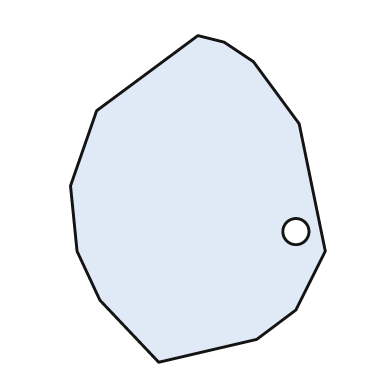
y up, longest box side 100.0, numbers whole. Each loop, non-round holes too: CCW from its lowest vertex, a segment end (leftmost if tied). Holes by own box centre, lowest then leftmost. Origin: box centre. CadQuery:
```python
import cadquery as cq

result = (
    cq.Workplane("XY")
    .moveTo(-12.0, -50.0)
    .lineTo(18.0, -43.0)
    .lineTo(30.0, -34.0)
    .lineTo(39.0, -16.0)
    .lineTo(31.0, 23.0)
    .lineTo(17.0, 42.0)
    .lineTo(8.0, 48.0)
    .lineTo(0.0, 50.0)
    .lineTo(-31.0, 27.0)
    .lineTo(-39.0, 4.0)
    .lineTo(-37.0, -16.0)
    .lineTo(-30.0, -31.0)
    .close()
    .moveTo(30.0, -10.0)
    .circle(4.0)
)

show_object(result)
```